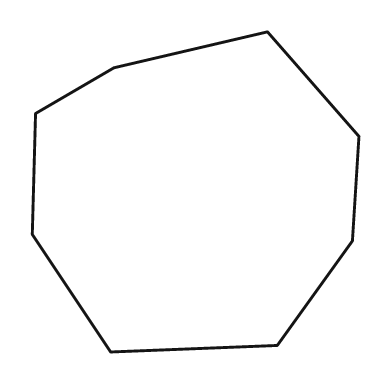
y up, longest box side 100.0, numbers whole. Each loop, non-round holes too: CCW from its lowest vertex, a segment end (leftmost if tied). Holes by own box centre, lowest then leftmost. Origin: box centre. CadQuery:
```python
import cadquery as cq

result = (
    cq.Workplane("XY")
    .moveTo(-26.0, -49.0)
    .lineTo(25.0, -47.0)
    .lineTo(48.0, -15.0)
    .lineTo(50.0, 17.0)
    .lineTo(22.0, 49.0)
    .lineTo(-25.0, 38.0)
    .lineTo(-49.0, 24.0)
    .lineTo(-50.0, -13.0)
    .close()
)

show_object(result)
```